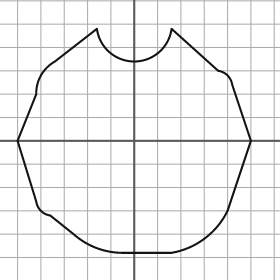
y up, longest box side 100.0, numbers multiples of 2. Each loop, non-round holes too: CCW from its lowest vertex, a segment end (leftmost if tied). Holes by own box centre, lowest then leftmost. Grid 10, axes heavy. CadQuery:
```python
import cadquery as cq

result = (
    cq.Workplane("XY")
    .moveTo(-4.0, -48.0)
    .lineTo(16.0, -48.0)
    .threePointArc((30.0, -42.0), (40.0, -30.0))
    .lineTo(50.0, 0.0)
    .lineTo(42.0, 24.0)
    .threePointArc((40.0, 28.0), (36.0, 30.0))
    .lineTo(16.0, 48.0)
    .threePointArc((0.0, 34.0), (-16.0, 48.0))
    .lineTo(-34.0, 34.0)
    .threePointArc((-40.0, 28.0), (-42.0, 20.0))
    .lineTo(-50.0, 0.0)
    .lineTo(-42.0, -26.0)
    .threePointArc((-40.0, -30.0), (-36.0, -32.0))
    .lineTo(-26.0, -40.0)
    .threePointArc((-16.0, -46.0), (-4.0, -48.0))
    .close()
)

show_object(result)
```